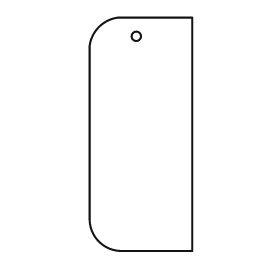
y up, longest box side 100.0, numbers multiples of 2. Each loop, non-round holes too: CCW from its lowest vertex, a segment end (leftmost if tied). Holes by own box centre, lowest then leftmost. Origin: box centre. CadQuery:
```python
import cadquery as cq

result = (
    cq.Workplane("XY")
    .moveTo(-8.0, -50.0)
    .lineTo(22.0, -50.0)
    .lineTo(22.0, 50.0)
    .lineTo(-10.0, 50.0)
    .threePointArc((-18.0, 46.0), (-22.0, 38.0))
    .lineTo(-22.0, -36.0)
    .threePointArc((-18.0, -46.0), (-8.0, -50.0))
    .close()
    .moveTo(-2.0, 42.0)
    .circle(2.0)
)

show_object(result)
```